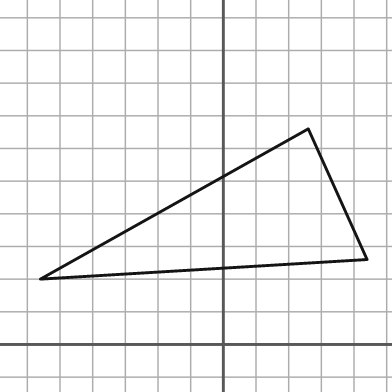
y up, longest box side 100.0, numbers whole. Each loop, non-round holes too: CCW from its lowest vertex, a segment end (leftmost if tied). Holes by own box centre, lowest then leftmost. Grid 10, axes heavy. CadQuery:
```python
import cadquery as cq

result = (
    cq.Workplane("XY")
    .moveTo(-56.0, 20.0)
    .lineTo(44.0, 26.0)
    .lineTo(26.0, 66.0)
    .close()
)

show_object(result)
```